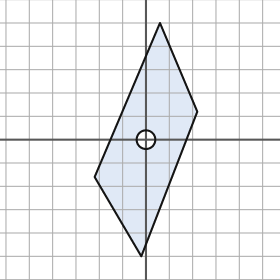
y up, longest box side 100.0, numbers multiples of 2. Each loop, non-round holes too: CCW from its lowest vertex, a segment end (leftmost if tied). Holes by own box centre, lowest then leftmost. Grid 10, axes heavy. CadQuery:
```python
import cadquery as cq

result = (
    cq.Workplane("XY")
    .moveTo(-2.0, -50.0)
    .lineTo(22.0, 12.0)
    .lineTo(6.0, 50.0)
    .lineTo(-22.0, -16.0)
    .close()
    .moveTo(0.0, 0.0)
    .circle(4.0)
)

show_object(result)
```